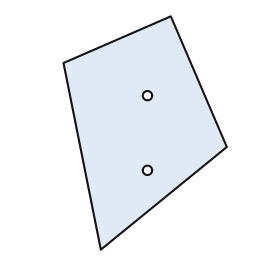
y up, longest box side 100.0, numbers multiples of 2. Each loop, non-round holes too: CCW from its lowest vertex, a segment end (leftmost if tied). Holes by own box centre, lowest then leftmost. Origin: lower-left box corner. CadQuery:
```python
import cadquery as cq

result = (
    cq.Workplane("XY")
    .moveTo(16.0, 0.0)
    .lineTo(70.0, 44.0)
    .lineTo(46.0, 100.0)
    .lineTo(0.0, 80.0)
    .close()
    .moveTo(36.0, 34.0)
    .circle(2.0)
    .moveTo(36.0, 66.0)
    .circle(2.0)
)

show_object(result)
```